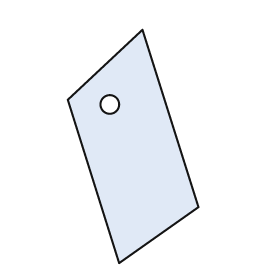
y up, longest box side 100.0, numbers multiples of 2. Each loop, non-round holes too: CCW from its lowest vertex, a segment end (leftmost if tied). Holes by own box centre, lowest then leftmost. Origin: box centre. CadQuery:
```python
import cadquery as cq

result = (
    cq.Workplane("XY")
    .moveTo(-6.0, -50.0)
    .lineTo(28.0, -26.0)
    .lineTo(4.0, 50.0)
    .lineTo(-28.0, 20.0)
    .close()
    .moveTo(-10.0, 18.0)
    .circle(4.0)
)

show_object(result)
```